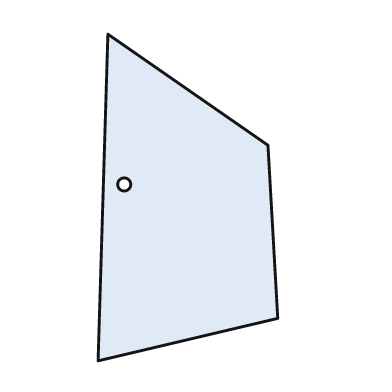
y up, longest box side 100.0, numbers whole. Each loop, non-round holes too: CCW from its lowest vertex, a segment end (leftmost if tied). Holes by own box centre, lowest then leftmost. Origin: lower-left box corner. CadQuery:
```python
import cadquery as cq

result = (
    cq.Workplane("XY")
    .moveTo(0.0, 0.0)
    .lineTo(55.0, 13.0)
    .lineTo(52.0, 66.0)
    .lineTo(3.0, 100.0)
    .close()
    .moveTo(8.0, 54.0)
    .circle(2.0)
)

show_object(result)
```